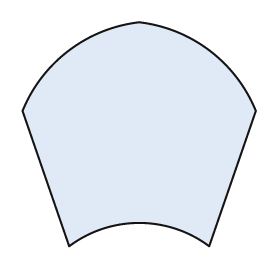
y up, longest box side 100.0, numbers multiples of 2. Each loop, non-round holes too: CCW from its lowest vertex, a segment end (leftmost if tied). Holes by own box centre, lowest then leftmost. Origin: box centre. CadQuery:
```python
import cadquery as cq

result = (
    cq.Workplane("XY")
    .moveTo(-30.0, -48.0)
    .threePointArc((0.0, -38.0), (30.0, -48.0))
    .lineTo(50.0, 10.0)
    .threePointArc((30.0, 36.0), (0.0, 48.0))
    .threePointArc((-30.0, 36.0), (-50.0, 10.0))
    .close()
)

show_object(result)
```